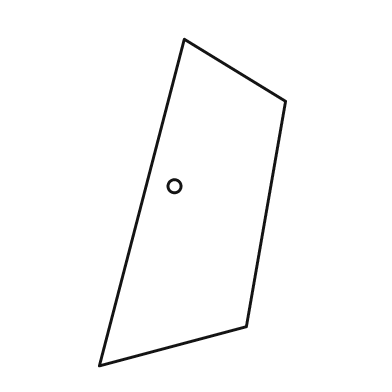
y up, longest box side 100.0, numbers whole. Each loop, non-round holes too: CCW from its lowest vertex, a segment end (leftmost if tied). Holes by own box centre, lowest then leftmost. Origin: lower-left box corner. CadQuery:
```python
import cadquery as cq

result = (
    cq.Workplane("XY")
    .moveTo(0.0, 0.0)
    .lineTo(45.0, 12.0)
    .lineTo(57.0, 81.0)
    .lineTo(26.0, 100.0)
    .close()
    .moveTo(23.0, 55.0)
    .circle(2.0)
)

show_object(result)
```